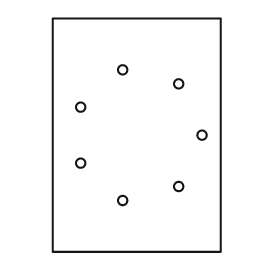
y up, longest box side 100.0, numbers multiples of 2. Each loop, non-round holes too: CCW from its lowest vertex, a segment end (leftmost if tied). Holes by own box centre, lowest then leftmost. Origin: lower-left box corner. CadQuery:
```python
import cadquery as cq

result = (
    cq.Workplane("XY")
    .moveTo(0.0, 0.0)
    .lineTo(72.0, 0.0)
    .lineTo(72.0, 100.0)
    .lineTo(0.0, 100.0)
    .close()
    .moveTo(30.0, 22.0)
    .circle(2.0)
    .moveTo(54.0, 28.0)
    .circle(2.0)
    .moveTo(12.0, 38.0)
    .circle(2.0)
    .moveTo(64.0, 50.0)
    .circle(2.0)
    .moveTo(12.0, 62.0)
    .circle(2.0)
    .moveTo(54.0, 72.0)
    .circle(2.0)
    .moveTo(30.0, 78.0)
    .circle(2.0)
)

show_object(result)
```